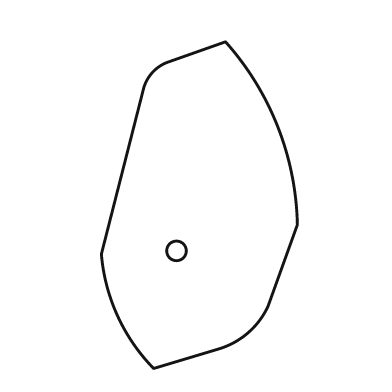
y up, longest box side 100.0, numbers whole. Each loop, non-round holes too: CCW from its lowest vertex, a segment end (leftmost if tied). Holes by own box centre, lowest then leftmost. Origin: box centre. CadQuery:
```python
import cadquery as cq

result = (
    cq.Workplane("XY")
    .moveTo(-14.0, -50.0)
    .lineTo(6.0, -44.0)
    .threePointArc((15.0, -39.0), (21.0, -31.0))
    .lineTo(30.0, -6.0)
    .threePointArc((24.0, 24.0), (8.0, 50.0))
    .lineTo(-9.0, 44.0)
    .threePointArc((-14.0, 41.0), (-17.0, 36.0))
    .lineTo(-30.0, -15.0)
    .threePointArc((-25.0, -34.0), (-14.0, -50.0))
    .close()
    .moveTo(-7.0, -14.0)
    .circle(3.0)
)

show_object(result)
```